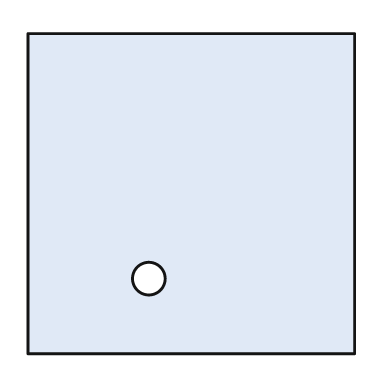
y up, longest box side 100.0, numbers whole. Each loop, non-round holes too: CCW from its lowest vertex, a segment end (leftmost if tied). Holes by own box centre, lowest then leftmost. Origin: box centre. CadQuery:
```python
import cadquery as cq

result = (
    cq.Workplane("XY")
    .moveTo(-50.0, -49.0)
    .lineTo(50.0, -49.0)
    .lineTo(50.0, 49.0)
    .lineTo(-50.0, 49.0)
    .close()
    .moveTo(-13.0, -26.0)
    .circle(5.0)
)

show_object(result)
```